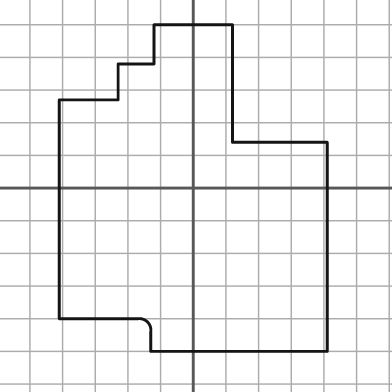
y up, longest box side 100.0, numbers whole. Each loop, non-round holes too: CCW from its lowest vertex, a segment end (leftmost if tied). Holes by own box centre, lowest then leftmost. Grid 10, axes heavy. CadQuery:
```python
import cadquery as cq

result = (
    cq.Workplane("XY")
    .moveTo(-13.0, -50.0)
    .lineTo(41.0, -50.0)
    .lineTo(41.0, 14.0)
    .lineTo(12.0, 14.0)
    .lineTo(12.0, 50.0)
    .lineTo(-12.0, 50.0)
    .lineTo(-12.0, 38.0)
    .lineTo(-23.0, 38.0)
    .lineTo(-23.0, 27.0)
    .lineTo(-41.0, 27.0)
    .lineTo(-41.0, -40.0)
    .lineTo(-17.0, -40.0)
    .threePointArc((-14.0, -41.0), (-13.0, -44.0))
    .close()
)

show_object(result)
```